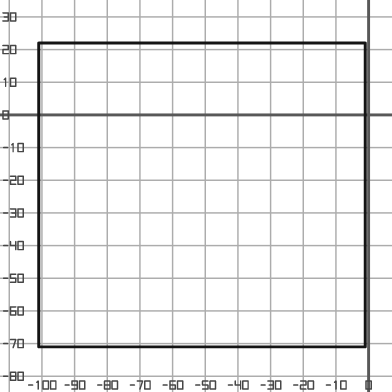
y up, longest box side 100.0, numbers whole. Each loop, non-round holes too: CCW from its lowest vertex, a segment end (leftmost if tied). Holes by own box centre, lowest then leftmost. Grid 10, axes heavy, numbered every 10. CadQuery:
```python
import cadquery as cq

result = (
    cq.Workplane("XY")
    .moveTo(-101.0, -71.0)
    .lineTo(-1.0, -71.0)
    .lineTo(-1.0, 22.0)
    .lineTo(-101.0, 22.0)
    .close()
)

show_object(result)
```